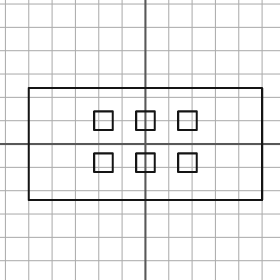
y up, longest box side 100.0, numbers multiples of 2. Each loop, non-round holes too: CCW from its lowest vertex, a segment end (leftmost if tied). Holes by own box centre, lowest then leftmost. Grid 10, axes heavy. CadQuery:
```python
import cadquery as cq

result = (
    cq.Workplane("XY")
    .moveTo(-50.0, -24.0)
    .lineTo(50.0, -24.0)
    .lineTo(50.0, 24.0)
    .lineTo(-50.0, 24.0)
    .close()
    .moveTo(-22.0, -12.0)
    .lineTo(-14.0, -12.0)
    .lineTo(-14.0, -4.0)
    .lineTo(-22.0, -4.0)
    .close()
    .moveTo(-4.0, -12.0)
    .lineTo(4.0, -12.0)
    .lineTo(4.0, -4.0)
    .lineTo(-4.0, -4.0)
    .close()
    .moveTo(14.0, -12.0)
    .lineTo(22.0, -12.0)
    .lineTo(22.0, -4.0)
    .lineTo(14.0, -4.0)
    .close()
    .moveTo(-22.0, 6.0)
    .lineTo(-14.0, 6.0)
    .lineTo(-14.0, 14.0)
    .lineTo(-22.0, 14.0)
    .close()
    .moveTo(-4.0, 6.0)
    .lineTo(4.0, 6.0)
    .lineTo(4.0, 14.0)
    .lineTo(-4.0, 14.0)
    .close()
    .moveTo(14.0, 6.0)
    .lineTo(22.0, 6.0)
    .lineTo(22.0, 14.0)
    .lineTo(14.0, 14.0)
    .close()
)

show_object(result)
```